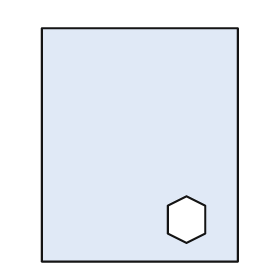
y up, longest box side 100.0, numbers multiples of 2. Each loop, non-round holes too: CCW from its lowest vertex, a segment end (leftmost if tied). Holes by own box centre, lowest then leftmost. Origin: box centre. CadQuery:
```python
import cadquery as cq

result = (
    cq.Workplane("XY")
    .moveTo(-42.0, -50.0)
    .lineTo(42.0, -50.0)
    .lineTo(42.0, 50.0)
    .lineTo(-42.0, 50.0)
    .close()
    .moveTo(20.0, -42.0)
    .lineTo(28.0, -38.0)
    .lineTo(28.0, -26.0)
    .lineTo(20.0, -22.0)
    .lineTo(12.0, -26.0)
    .lineTo(12.0, -38.0)
    .close()
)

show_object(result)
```